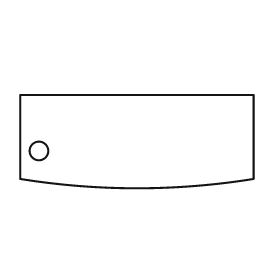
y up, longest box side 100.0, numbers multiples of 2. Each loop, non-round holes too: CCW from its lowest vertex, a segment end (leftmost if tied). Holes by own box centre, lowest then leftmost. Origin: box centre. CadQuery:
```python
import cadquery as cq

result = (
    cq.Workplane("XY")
    .moveTo(-50.0, -16.0)
    .threePointArc((0.0, -20.0), (50.0, -16.0))
    .lineTo(50.0, 20.0)
    .lineTo(-50.0, 20.0)
    .close()
    .moveTo(-42.0, -4.0)
    .circle(4.0)
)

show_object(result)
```